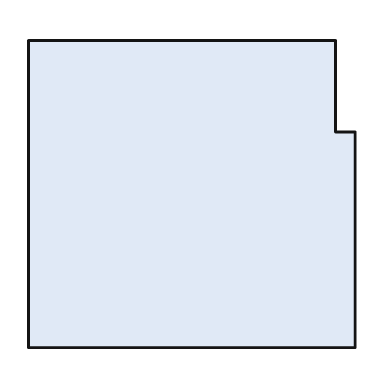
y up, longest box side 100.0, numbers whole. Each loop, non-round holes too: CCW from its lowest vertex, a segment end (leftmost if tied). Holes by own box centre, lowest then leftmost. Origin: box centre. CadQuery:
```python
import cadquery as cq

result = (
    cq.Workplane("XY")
    .moveTo(-50.0, -47.0)
    .lineTo(50.0, -47.0)
    .lineTo(50.0, 19.0)
    .lineTo(44.0, 19.0)
    .lineTo(44.0, 47.0)
    .lineTo(-50.0, 47.0)
    .close()
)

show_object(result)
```